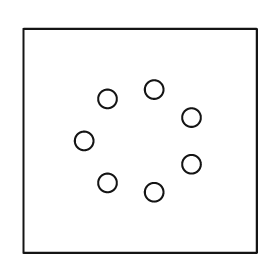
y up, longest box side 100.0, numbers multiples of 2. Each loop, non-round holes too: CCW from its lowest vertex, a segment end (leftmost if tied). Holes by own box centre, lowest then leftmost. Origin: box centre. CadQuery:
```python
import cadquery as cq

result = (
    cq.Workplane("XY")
    .moveTo(-50.0, -48.0)
    .lineTo(50.0, -48.0)
    .lineTo(50.0, 48.0)
    .lineTo(-50.0, 48.0)
    .close()
    .moveTo(6.0, -22.0)
    .circle(4.0)
    .moveTo(-14.0, -18.0)
    .circle(4.0)
    .moveTo(22.0, -10.0)
    .circle(4.0)
    .moveTo(-24.0, 0.0)
    .circle(4.0)
    .moveTo(22.0, 10.0)
    .circle(4.0)
    .moveTo(-14.0, 18.0)
    .circle(4.0)
    .moveTo(6.0, 22.0)
    .circle(4.0)
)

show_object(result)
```